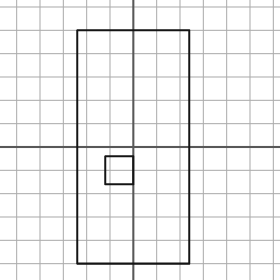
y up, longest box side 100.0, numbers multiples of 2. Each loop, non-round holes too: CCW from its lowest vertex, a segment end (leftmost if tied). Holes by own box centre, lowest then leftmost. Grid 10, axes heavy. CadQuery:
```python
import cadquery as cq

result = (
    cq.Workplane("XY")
    .moveTo(-24.0, -50.0)
    .lineTo(24.0, -50.0)
    .lineTo(24.0, 50.0)
    .lineTo(-24.0, 50.0)
    .close()
    .moveTo(-12.0, -16.0)
    .lineTo(0.0, -16.0)
    .lineTo(0.0, -4.0)
    .lineTo(-12.0, -4.0)
    .close()
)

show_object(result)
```